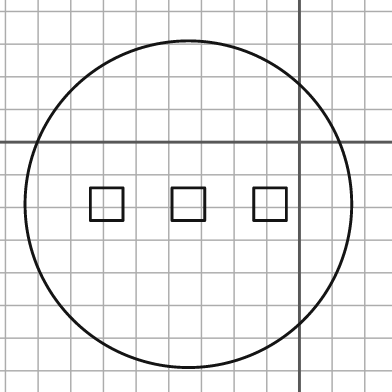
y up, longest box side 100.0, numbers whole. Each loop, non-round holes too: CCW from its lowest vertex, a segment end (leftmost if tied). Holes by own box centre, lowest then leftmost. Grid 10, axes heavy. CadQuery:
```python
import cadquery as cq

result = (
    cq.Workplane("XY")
    .moveTo(-34.0, -19.0)
    .circle(50.0)
    .moveTo(-64.0, -24.0)
    .lineTo(-54.0, -24.0)
    .lineTo(-54.0, -14.0)
    .lineTo(-64.0, -14.0)
    .close()
    .moveTo(-39.0, -24.0)
    .lineTo(-29.0, -24.0)
    .lineTo(-29.0, -14.0)
    .lineTo(-39.0, -14.0)
    .close()
    .moveTo(-14.0, -24.0)
    .lineTo(-4.0, -24.0)
    .lineTo(-4.0, -14.0)
    .lineTo(-14.0, -14.0)
    .close()
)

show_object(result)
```